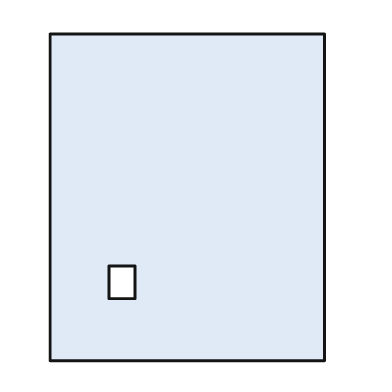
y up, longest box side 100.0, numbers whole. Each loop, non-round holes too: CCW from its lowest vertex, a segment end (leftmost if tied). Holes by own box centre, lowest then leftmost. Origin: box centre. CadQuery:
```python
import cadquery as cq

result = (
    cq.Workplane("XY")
    .moveTo(-42.0, -50.0)
    .lineTo(42.0, -50.0)
    .lineTo(42.0, 50.0)
    .lineTo(-42.0, 50.0)
    .close()
    .moveTo(-24.0, -31.0)
    .lineTo(-16.0, -31.0)
    .lineTo(-16.0, -21.0)
    .lineTo(-24.0, -21.0)
    .close()
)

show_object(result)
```